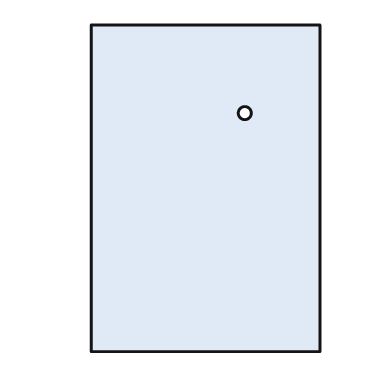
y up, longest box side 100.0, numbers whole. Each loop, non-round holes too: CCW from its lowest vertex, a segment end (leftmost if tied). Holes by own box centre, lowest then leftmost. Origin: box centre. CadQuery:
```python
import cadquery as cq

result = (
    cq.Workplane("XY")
    .moveTo(-35.0, -50.0)
    .lineTo(35.0, -50.0)
    .lineTo(35.0, 50.0)
    .lineTo(-35.0, 50.0)
    .close()
    .moveTo(12.0, 23.0)
    .circle(2.0)
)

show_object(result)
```